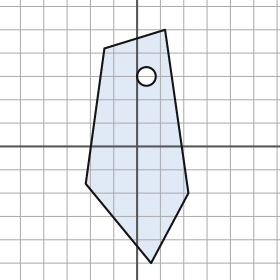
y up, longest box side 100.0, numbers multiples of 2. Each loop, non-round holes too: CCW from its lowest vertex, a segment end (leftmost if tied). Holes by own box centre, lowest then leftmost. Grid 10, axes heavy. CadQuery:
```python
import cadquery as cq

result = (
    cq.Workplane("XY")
    .moveTo(6.0, -50.0)
    .lineTo(22.0, -20.0)
    .lineTo(12.0, 50.0)
    .lineTo(-14.0, 42.0)
    .lineTo(-22.0, -16.0)
    .close()
    .moveTo(4.0, 30.0)
    .circle(4.0)
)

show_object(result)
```